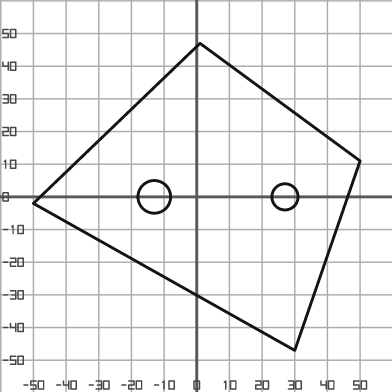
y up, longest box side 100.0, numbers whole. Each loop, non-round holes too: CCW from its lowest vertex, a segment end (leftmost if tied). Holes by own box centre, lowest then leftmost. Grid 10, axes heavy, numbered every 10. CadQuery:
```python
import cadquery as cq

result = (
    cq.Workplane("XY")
    .moveTo(30.0, -47.0)
    .lineTo(50.0, 11.0)
    .lineTo(1.0, 47.0)
    .lineTo(-50.0, -2.0)
    .close()
    .moveTo(-13.0, 0.0)
    .circle(5.0)
    .moveTo(27.0, 0.0)
    .circle(4.0)
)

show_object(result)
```